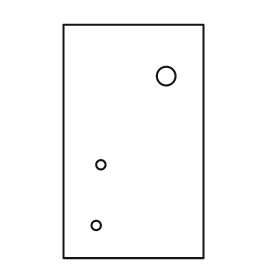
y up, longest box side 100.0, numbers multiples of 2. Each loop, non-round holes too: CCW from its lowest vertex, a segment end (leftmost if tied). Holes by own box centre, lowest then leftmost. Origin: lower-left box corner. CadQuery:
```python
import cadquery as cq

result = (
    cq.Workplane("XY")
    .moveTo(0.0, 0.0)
    .lineTo(60.0, 0.0)
    .lineTo(60.0, 100.0)
    .lineTo(0.0, 100.0)
    .close()
    .moveTo(14.0, 14.0)
    .circle(2.0)
    .moveTo(16.0, 40.0)
    .circle(2.0)
    .moveTo(44.0, 78.0)
    .circle(4.0)
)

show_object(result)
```